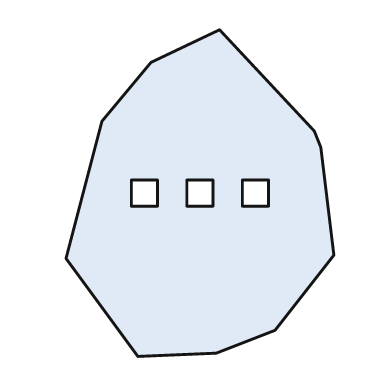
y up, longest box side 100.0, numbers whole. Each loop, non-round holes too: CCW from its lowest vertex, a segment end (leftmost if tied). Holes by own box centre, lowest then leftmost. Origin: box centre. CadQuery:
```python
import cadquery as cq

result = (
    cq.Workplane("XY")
    .moveTo(-19.0, -50.0)
    .lineTo(5.0, -49.0)
    .lineTo(23.0, -42.0)
    .lineTo(41.0, -19.0)
    .lineTo(37.0, 14.0)
    .lineTo(35.0, 19.0)
    .lineTo(6.0, 50.0)
    .lineTo(-15.0, 40.0)
    .lineTo(-30.0, 22.0)
    .lineTo(-41.0, -20.0)
    .close()
    .moveTo(-21.0, -4.0)
    .lineTo(-13.0, -4.0)
    .lineTo(-13.0, 4.0)
    .lineTo(-21.0, 4.0)
    .close()
    .moveTo(-4.0, -4.0)
    .lineTo(4.0, -4.0)
    .lineTo(4.0, 4.0)
    .lineTo(-4.0, 4.0)
    .close()
    .moveTo(13.0, -4.0)
    .lineTo(21.0, -4.0)
    .lineTo(21.0, 4.0)
    .lineTo(13.0, 4.0)
    .close()
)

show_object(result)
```